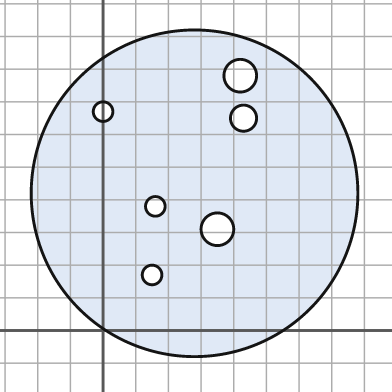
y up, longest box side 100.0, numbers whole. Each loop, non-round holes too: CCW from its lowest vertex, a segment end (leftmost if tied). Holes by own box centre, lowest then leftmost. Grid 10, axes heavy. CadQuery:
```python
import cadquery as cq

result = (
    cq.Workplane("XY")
    .moveTo(28.0, 42.0)
    .circle(50.0)
    .moveTo(15.0, 17.0)
    .circle(3.0)
    .moveTo(35.0, 31.0)
    .circle(5.0)
    .moveTo(16.0, 38.0)
    .circle(3.0)
    .moveTo(43.0, 65.0)
    .circle(4.0)
    .moveTo(0.0, 67.0)
    .circle(3.0)
    .moveTo(42.0, 78.0)
    .circle(5.0)
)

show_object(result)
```